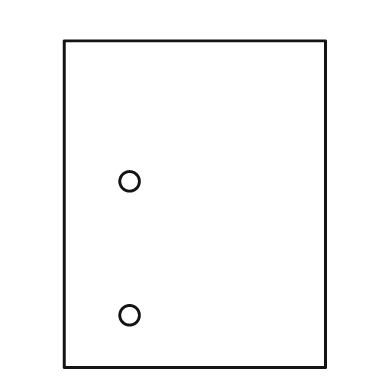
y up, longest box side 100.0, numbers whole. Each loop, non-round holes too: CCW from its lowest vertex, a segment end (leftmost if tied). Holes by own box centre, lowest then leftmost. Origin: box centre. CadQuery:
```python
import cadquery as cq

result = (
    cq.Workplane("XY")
    .moveTo(-40.0, -50.0)
    .lineTo(40.0, -50.0)
    .lineTo(40.0, 50.0)
    .lineTo(-40.0, 50.0)
    .close()
    .moveTo(-20.0, -34.0)
    .circle(3.0)
    .moveTo(-20.0, 7.0)
    .circle(3.0)
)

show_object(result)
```